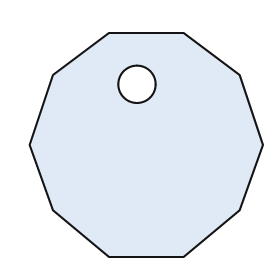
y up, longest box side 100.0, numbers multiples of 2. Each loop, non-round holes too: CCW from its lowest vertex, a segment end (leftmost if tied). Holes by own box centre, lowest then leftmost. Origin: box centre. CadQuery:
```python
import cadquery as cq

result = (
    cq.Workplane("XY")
    .moveTo(-16.0, -48.0)
    .lineTo(16.0, -48.0)
    .lineTo(40.0, -28.0)
    .lineTo(50.0, 0.0)
    .lineTo(40.0, 30.0)
    .lineTo(16.0, 48.0)
    .lineTo(-16.0, 48.0)
    .lineTo(-40.0, 30.0)
    .lineTo(-50.0, 0.0)
    .lineTo(-40.0, -28.0)
    .close()
    .moveTo(-4.0, 26.0)
    .circle(8.0)
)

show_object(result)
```